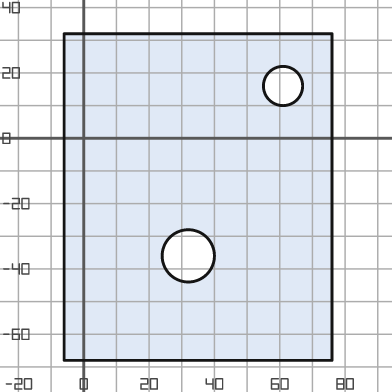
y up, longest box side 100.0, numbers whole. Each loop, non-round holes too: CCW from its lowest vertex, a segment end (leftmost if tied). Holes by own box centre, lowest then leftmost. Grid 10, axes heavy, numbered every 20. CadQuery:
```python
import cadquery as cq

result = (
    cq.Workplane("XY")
    .moveTo(-6.0, -68.0)
    .lineTo(76.0, -68.0)
    .lineTo(76.0, 32.0)
    .lineTo(-6.0, 32.0)
    .close()
    .moveTo(32.0, -36.0)
    .circle(8.0)
    .moveTo(61.0, 16.0)
    .circle(6.0)
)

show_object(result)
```